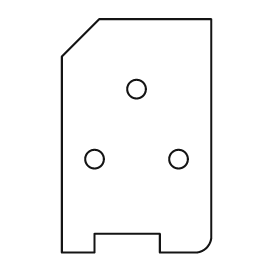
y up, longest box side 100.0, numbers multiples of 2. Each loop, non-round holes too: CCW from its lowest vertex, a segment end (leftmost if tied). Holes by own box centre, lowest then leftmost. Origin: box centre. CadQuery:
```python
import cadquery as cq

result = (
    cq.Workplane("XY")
    .moveTo(-32.0, -50.0)
    .lineTo(-18.0, -50.0)
    .lineTo(-18.0, -42.0)
    .lineTo(10.0, -42.0)
    .lineTo(10.0, -50.0)
    .lineTo(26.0, -50.0)
    .threePointArc((30.0, -48.0), (32.0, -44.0))
    .lineTo(32.0, 50.0)
    .lineTo(-16.0, 50.0)
    .lineTo(-32.0, 34.0)
    .close()
    .moveTo(-18.0, -10.0)
    .circle(4.0)
    .moveTo(18.0, -10.0)
    .circle(4.0)
    .moveTo(0.0, 20.0)
    .circle(4.0)
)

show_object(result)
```